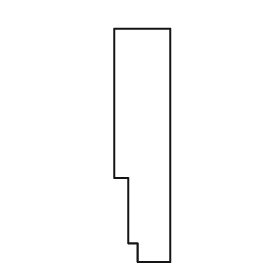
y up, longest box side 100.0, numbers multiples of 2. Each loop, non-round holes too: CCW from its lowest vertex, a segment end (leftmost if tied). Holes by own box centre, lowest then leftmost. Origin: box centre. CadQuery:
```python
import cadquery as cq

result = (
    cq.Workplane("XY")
    .moveTo(-2.0, -50.0)
    .lineTo(12.0, -50.0)
    .lineTo(12.0, 50.0)
    .lineTo(-12.0, 50.0)
    .lineTo(-12.0, -14.0)
    .lineTo(-6.0, -14.0)
    .lineTo(-6.0, -42.0)
    .lineTo(-2.0, -42.0)
    .close()
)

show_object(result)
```